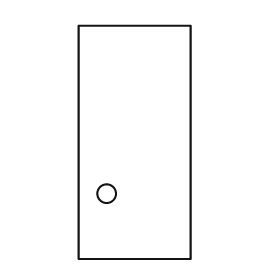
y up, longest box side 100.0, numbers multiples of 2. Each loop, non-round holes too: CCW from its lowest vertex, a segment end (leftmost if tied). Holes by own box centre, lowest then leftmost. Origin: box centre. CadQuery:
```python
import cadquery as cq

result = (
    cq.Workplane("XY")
    .moveTo(-24.0, -50.0)
    .lineTo(24.0, -50.0)
    .lineTo(24.0, 50.0)
    .lineTo(-24.0, 50.0)
    .close()
    .moveTo(-12.0, -22.0)
    .circle(4.0)
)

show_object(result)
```